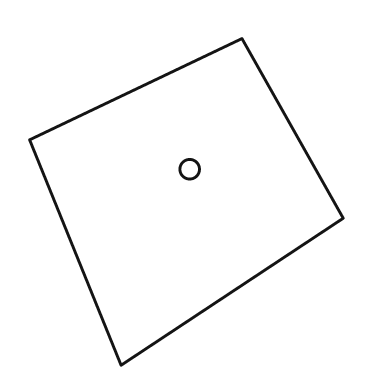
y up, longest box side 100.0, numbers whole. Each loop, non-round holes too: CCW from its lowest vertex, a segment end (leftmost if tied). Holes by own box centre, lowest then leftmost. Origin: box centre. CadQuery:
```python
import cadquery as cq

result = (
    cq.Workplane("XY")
    .moveTo(-20.0, -50.0)
    .lineTo(48.0, -5.0)
    .lineTo(17.0, 50.0)
    .lineTo(-48.0, 19.0)
    .close()
    .moveTo(1.0, 10.0)
    .circle(3.0)
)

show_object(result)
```